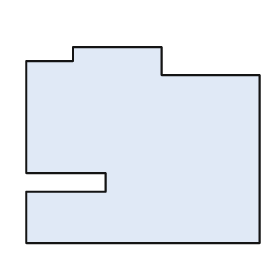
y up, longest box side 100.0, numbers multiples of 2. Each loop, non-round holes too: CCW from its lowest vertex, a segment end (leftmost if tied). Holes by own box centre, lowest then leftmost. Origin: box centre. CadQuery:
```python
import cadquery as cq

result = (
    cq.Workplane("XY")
    .moveTo(-50.0, -42.0)
    .lineTo(50.0, -42.0)
    .lineTo(50.0, 30.0)
    .lineTo(8.0, 30.0)
    .lineTo(8.0, 42.0)
    .lineTo(-30.0, 42.0)
    .lineTo(-30.0, 36.0)
    .lineTo(-50.0, 36.0)
    .lineTo(-50.0, -12.0)
    .lineTo(-16.0, -12.0)
    .lineTo(-16.0, -20.0)
    .lineTo(-50.0, -20.0)
    .close()
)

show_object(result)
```